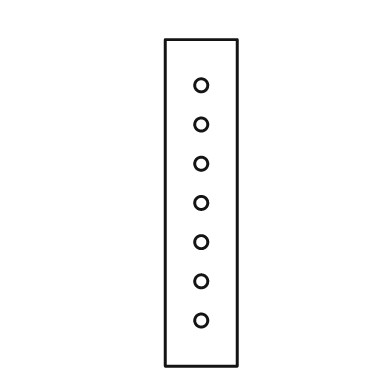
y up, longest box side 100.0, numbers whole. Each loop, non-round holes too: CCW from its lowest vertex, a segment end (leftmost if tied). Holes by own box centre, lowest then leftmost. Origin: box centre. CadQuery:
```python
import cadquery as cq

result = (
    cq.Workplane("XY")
    .moveTo(-11.0, -50.0)
    .lineTo(11.0, -50.0)
    .lineTo(11.0, 50.0)
    .lineTo(-11.0, 50.0)
    .close()
    .moveTo(0.0, -36.0)
    .circle(2.0)
    .moveTo(0.0, -24.0)
    .circle(2.0)
    .moveTo(0.0, -12.0)
    .circle(2.0)
    .moveTo(0.0, 0.0)
    .circle(2.0)
    .moveTo(0.0, 12.0)
    .circle(2.0)
    .moveTo(0.0, 24.0)
    .circle(2.0)
    .moveTo(0.0, 36.0)
    .circle(2.0)
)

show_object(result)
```